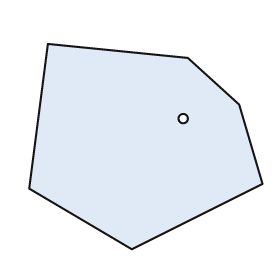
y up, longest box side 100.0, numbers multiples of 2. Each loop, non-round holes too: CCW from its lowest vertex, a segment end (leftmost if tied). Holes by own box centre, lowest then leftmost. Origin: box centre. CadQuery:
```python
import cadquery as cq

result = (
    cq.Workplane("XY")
    .moveTo(-6.0, -44.0)
    .lineTo(50.0, -16.0)
    .lineTo(40.0, 18.0)
    .lineTo(18.0, 38.0)
    .lineTo(-42.0, 44.0)
    .lineTo(-50.0, -18.0)
    .close()
    .moveTo(16.0, 12.0)
    .circle(2.0)
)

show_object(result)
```